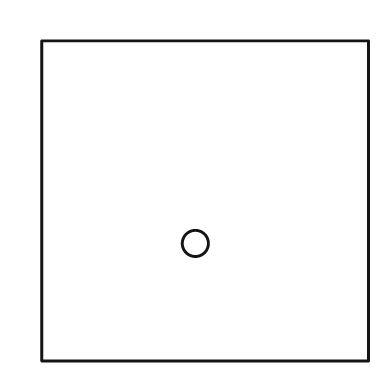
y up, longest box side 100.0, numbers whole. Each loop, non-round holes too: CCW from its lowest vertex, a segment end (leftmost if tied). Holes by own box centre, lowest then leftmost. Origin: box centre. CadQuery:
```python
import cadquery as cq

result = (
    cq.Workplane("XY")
    .moveTo(-50.0, -49.0)
    .lineTo(50.0, -49.0)
    .lineTo(50.0, 49.0)
    .lineTo(-50.0, 49.0)
    .close()
    .moveTo(-3.0, -13.0)
    .circle(4.0)
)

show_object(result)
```